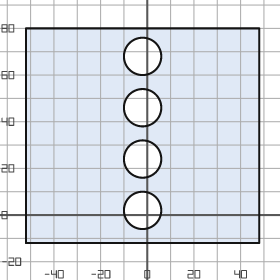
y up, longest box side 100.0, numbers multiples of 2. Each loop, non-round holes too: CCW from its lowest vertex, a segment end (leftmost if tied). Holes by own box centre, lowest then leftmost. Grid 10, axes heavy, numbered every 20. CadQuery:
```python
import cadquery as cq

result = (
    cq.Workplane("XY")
    .moveTo(-52.0, -12.0)
    .lineTo(48.0, -12.0)
    .lineTo(48.0, 80.0)
    .lineTo(-52.0, 80.0)
    .close()
    .moveTo(-2.0, 2.0)
    .circle(8.0)
    .moveTo(-2.0, 24.0)
    .circle(8.0)
    .moveTo(-2.0, 46.0)
    .circle(8.0)
    .moveTo(-2.0, 68.0)
    .circle(8.0)
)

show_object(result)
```